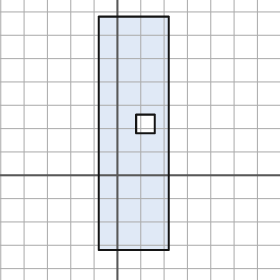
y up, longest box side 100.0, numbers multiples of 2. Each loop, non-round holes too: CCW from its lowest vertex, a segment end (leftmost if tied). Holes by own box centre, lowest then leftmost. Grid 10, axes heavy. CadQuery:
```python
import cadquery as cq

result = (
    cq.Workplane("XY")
    .moveTo(-8.0, -32.0)
    .lineTo(22.0, -32.0)
    .lineTo(22.0, 68.0)
    .lineTo(-8.0, 68.0)
    .close()
    .moveTo(8.0, 18.0)
    .lineTo(16.0, 18.0)
    .lineTo(16.0, 26.0)
    .lineTo(8.0, 26.0)
    .close()
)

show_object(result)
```